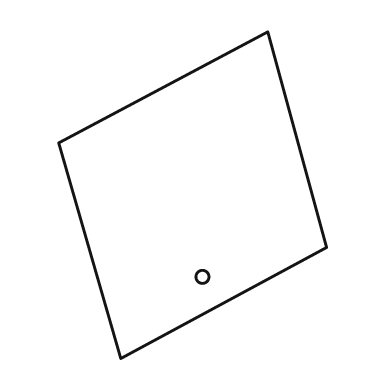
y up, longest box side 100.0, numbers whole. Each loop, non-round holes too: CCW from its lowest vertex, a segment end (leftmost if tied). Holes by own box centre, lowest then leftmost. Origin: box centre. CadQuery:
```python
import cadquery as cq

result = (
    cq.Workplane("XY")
    .moveTo(-22.0, -50.0)
    .lineTo(41.0, -16.0)
    .lineTo(23.0, 50.0)
    .lineTo(-41.0, 16.0)
    .close()
    .moveTo(3.0, -25.0)
    .circle(2.0)
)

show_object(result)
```